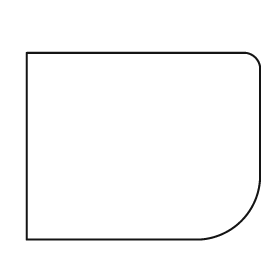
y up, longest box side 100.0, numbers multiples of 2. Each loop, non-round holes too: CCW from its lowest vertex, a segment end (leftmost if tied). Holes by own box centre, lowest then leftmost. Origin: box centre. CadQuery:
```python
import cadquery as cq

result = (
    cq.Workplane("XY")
    .moveTo(-50.0, -40.0)
    .lineTo(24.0, -40.0)
    .threePointArc((42.0, -32.0), (50.0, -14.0))
    .lineTo(50.0, 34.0)
    .threePointArc((48.0, 38.0), (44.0, 40.0))
    .lineTo(-50.0, 40.0)
    .close()
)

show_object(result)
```